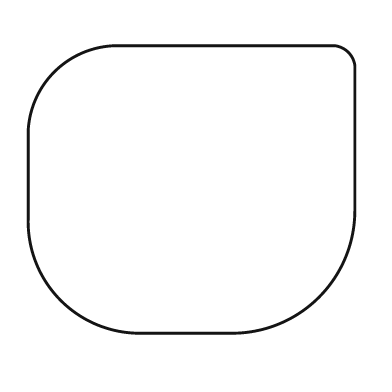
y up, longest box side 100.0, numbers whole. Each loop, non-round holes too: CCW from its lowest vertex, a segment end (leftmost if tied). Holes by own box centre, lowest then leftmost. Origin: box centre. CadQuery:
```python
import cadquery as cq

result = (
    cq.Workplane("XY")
    .moveTo(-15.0, -44.0)
    .lineTo(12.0, -44.0)
    .threePointArc((39.0, -33.0), (50.0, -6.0))
    .lineTo(50.0, 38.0)
    .threePointArc((48.0, 42.0), (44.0, 44.0))
    .lineTo(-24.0, 44.0)
    .threePointArc((-42.0, 36.0), (-50.0, 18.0))
    .lineTo(-50.0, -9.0)
    .threePointArc((-40.0, -34.0), (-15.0, -44.0))
    .close()
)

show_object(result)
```